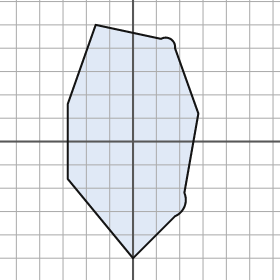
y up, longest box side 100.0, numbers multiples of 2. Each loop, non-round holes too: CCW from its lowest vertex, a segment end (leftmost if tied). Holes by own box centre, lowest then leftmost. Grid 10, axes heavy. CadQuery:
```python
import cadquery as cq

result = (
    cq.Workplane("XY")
    .moveTo(0.0, -50.0)
    .lineTo(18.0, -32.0)
    .threePointArc((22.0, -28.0), (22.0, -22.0))
    .lineTo(28.0, 12.0)
    .lineTo(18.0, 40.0)
    .threePointArc((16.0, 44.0), (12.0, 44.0))
    .lineTo(-16.0, 50.0)
    .lineTo(-28.0, 16.0)
    .lineTo(-28.0, -16.0)
    .close()
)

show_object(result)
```